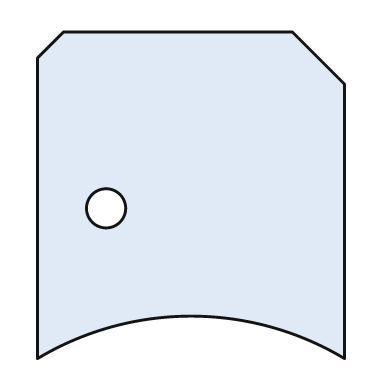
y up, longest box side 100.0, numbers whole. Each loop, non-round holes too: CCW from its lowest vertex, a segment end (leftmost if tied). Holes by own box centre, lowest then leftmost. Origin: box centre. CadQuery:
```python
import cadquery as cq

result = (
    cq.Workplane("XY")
    .moveTo(-47.0, -50.0)
    .threePointArc((0.0, -37.0), (47.0, -50.0))
    .lineTo(47.0, 34.0)
    .lineTo(31.0, 50.0)
    .lineTo(-39.0, 50.0)
    .lineTo(-47.0, 42.0)
    .close()
    .moveTo(-26.0, -4.0)
    .circle(6.0)
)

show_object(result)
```